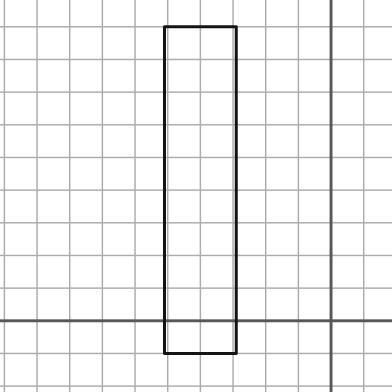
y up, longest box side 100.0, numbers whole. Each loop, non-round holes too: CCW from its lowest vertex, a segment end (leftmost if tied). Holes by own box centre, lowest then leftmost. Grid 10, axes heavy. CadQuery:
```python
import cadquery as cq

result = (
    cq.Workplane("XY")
    .moveTo(-51.0, -10.0)
    .lineTo(-29.0, -10.0)
    .lineTo(-29.0, 90.0)
    .lineTo(-51.0, 90.0)
    .close()
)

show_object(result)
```